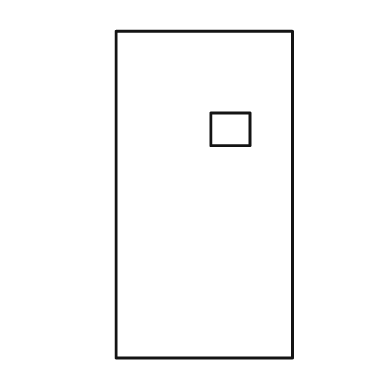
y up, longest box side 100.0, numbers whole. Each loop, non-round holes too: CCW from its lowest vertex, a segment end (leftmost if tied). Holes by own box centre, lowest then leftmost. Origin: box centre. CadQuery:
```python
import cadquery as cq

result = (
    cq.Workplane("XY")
    .moveTo(-27.0, -50.0)
    .lineTo(27.0, -50.0)
    .lineTo(27.0, 50.0)
    .lineTo(-27.0, 50.0)
    .close()
    .moveTo(2.0, 15.0)
    .lineTo(14.0, 15.0)
    .lineTo(14.0, 25.0)
    .lineTo(2.0, 25.0)
    .close()
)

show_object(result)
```